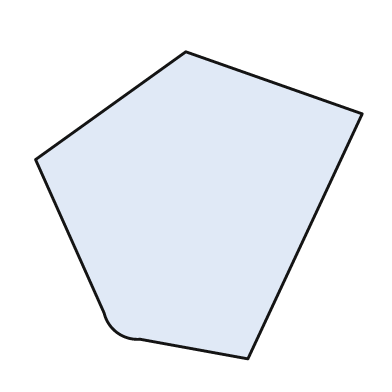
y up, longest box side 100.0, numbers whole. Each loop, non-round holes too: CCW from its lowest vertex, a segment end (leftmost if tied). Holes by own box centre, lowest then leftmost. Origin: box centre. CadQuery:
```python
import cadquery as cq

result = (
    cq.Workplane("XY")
    .moveTo(15.0, -47.0)
    .lineTo(50.0, 28.0)
    .lineTo(-4.0, 47.0)
    .lineTo(-50.0, 14.0)
    .lineTo(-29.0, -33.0)
    .threePointArc((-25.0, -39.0), (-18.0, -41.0))
    .close()
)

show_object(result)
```